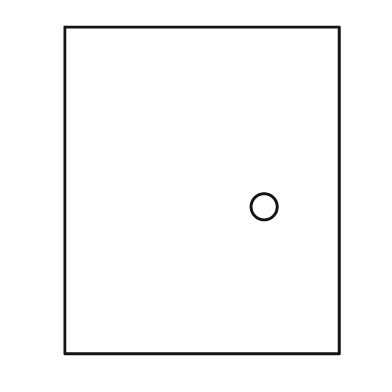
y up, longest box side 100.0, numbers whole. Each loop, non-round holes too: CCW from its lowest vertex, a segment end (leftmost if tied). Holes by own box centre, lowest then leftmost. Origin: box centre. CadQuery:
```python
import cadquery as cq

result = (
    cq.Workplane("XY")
    .moveTo(-42.0, -50.0)
    .lineTo(42.0, -50.0)
    .lineTo(42.0, 50.0)
    .lineTo(-42.0, 50.0)
    .close()
    .moveTo(19.0, -5.0)
    .circle(4.0)
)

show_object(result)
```